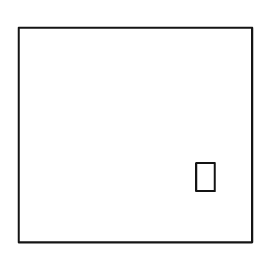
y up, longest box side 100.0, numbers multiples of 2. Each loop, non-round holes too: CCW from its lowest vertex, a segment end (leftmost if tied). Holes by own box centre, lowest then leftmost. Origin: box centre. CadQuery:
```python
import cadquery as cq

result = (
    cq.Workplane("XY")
    .moveTo(-50.0, -46.0)
    .lineTo(50.0, -46.0)
    .lineTo(50.0, 46.0)
    .lineTo(-50.0, 46.0)
    .close()
    .moveTo(26.0, -24.0)
    .lineTo(34.0, -24.0)
    .lineTo(34.0, -12.0)
    .lineTo(26.0, -12.0)
    .close()
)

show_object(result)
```